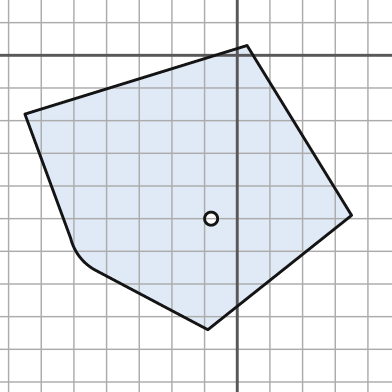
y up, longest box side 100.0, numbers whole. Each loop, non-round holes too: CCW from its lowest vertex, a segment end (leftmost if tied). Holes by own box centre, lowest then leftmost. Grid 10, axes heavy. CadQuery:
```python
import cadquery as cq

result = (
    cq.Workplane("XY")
    .moveTo(-9.0, -84.0)
    .lineTo(35.0, -49.0)
    .lineTo(3.0, 3.0)
    .lineTo(-65.0, -18.0)
    .lineTo(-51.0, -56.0)
    .threePointArc((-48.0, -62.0), (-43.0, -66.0))
    .close()
    .moveTo(-8.0, -50.0)
    .circle(2.0)
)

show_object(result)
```